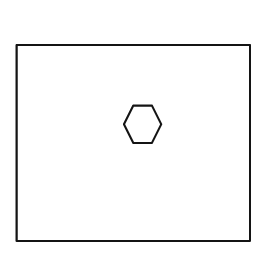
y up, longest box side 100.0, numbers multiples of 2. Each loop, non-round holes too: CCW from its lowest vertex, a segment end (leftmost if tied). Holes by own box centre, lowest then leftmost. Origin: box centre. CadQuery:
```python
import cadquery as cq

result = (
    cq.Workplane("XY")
    .moveTo(-50.0, -42.0)
    .lineTo(50.0, -42.0)
    .lineTo(50.0, 42.0)
    .lineTo(-50.0, 42.0)
    .close()
    .moveTo(0.0, 0.0)
    .lineTo(8.0, 0.0)
    .lineTo(12.0, 8.0)
    .lineTo(8.0, 16.0)
    .lineTo(0.0, 16.0)
    .lineTo(-4.0, 8.0)
    .close()
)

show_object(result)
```